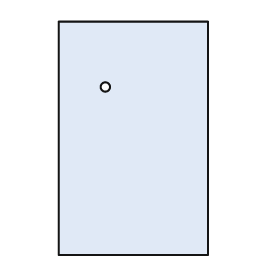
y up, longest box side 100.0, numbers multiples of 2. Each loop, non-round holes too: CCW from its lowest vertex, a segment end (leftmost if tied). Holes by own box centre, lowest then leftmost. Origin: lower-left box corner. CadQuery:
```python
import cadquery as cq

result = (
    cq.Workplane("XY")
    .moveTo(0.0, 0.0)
    .lineTo(64.0, 0.0)
    .lineTo(64.0, 100.0)
    .lineTo(0.0, 100.0)
    .close()
    .moveTo(20.0, 72.0)
    .circle(2.0)
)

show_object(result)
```